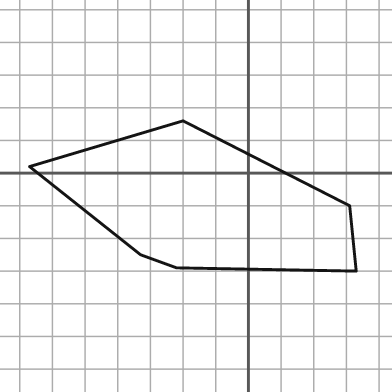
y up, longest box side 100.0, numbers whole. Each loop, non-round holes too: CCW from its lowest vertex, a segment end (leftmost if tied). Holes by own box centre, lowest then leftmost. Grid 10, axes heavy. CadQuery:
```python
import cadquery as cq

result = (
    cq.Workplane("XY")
    .moveTo(33.0, -30.0)
    .lineTo(31.0, -10.0)
    .lineTo(-20.0, 16.0)
    .lineTo(-67.0, 2.0)
    .lineTo(-33.0, -25.0)
    .lineTo(-22.0, -29.0)
    .close()
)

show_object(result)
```